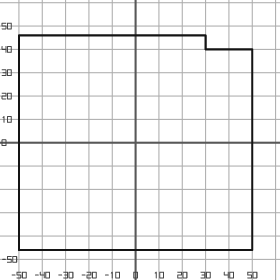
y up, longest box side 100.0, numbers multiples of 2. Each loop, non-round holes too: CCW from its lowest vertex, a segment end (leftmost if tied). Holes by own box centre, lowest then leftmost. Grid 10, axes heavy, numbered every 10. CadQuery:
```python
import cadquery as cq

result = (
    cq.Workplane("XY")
    .moveTo(-50.0, -46.0)
    .lineTo(50.0, -46.0)
    .lineTo(50.0, 40.0)
    .lineTo(30.0, 40.0)
    .lineTo(30.0, 46.0)
    .lineTo(-50.0, 46.0)
    .close()
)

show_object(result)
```